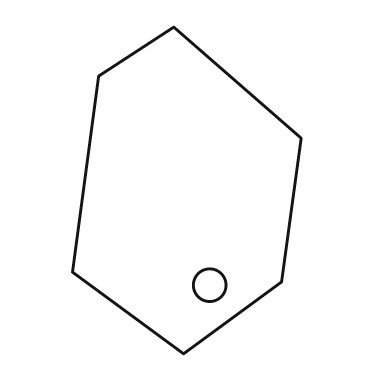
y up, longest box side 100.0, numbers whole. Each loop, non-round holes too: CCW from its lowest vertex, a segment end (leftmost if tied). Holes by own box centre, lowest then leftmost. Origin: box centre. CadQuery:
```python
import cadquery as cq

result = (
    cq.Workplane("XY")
    .moveTo(-1.0, -50.0)
    .lineTo(29.0, -28.0)
    .lineTo(35.0, 16.0)
    .lineTo(-4.0, 50.0)
    .lineTo(-27.0, 35.0)
    .lineTo(-35.0, -25.0)
    .close()
    .moveTo(7.0, -29.0)
    .circle(5.0)
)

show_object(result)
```